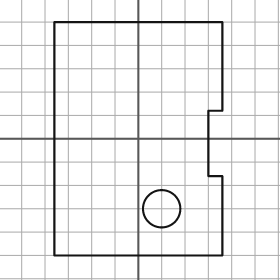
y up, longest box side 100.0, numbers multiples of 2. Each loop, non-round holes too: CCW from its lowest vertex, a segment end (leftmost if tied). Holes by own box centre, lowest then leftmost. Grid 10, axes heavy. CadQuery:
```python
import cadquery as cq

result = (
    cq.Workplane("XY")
    .moveTo(-36.0, -50.0)
    .lineTo(36.0, -50.0)
    .lineTo(36.0, -16.0)
    .lineTo(30.0, -16.0)
    .lineTo(30.0, 12.0)
    .lineTo(36.0, 12.0)
    .lineTo(36.0, 50.0)
    .lineTo(-36.0, 50.0)
    .close()
    .moveTo(10.0, -30.0)
    .circle(8.0)
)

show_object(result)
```